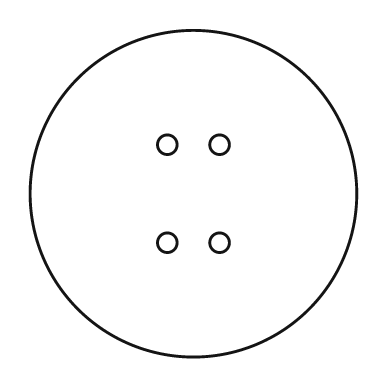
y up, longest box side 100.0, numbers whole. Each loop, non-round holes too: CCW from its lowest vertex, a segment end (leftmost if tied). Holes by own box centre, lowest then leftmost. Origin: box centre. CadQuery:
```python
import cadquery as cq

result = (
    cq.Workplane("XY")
    .moveTo(0.0, 0.0)
    .circle(50.0)
    .moveTo(-8.0, -15.0)
    .circle(3.0)
    .moveTo(8.0, -15.0)
    .circle(3.0)
    .moveTo(-8.0, 15.0)
    .circle(3.0)
    .moveTo(8.0, 15.0)
    .circle(3.0)
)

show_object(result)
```